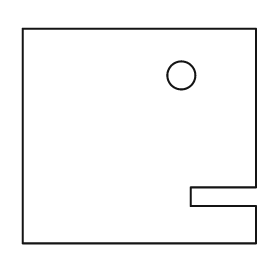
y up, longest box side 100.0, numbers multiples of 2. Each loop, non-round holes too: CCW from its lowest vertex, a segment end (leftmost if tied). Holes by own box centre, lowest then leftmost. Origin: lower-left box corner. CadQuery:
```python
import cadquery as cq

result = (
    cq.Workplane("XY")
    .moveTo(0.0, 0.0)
    .lineTo(100.0, 0.0)
    .lineTo(100.0, 16.0)
    .lineTo(72.0, 16.0)
    .lineTo(72.0, 24.0)
    .lineTo(100.0, 24.0)
    .lineTo(100.0, 92.0)
    .lineTo(0.0, 92.0)
    .close()
    .moveTo(68.0, 72.0)
    .circle(6.0)
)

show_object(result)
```